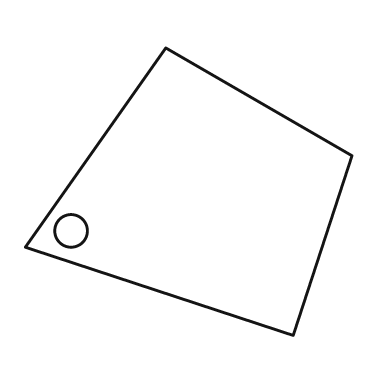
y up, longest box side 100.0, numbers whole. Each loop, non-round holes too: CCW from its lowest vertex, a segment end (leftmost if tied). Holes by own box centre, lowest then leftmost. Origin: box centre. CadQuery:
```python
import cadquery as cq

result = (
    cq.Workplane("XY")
    .moveTo(32.0, -44.0)
    .lineTo(50.0, 11.0)
    .lineTo(-7.0, 44.0)
    .lineTo(-50.0, -17.0)
    .close()
    .moveTo(-36.0, -12.0)
    .circle(5.0)
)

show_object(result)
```